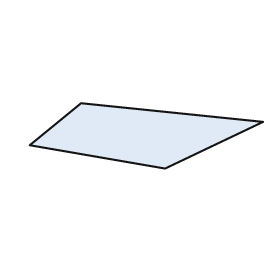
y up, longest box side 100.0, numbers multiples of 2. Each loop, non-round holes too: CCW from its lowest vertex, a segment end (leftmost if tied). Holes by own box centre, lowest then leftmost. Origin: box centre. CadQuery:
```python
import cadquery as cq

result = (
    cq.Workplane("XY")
    .moveTo(8.0, -14.0)
    .lineTo(50.0, 6.0)
    .lineTo(-28.0, 14.0)
    .lineTo(-50.0, -4.0)
    .close()
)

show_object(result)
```